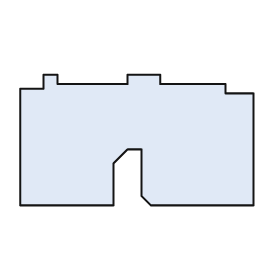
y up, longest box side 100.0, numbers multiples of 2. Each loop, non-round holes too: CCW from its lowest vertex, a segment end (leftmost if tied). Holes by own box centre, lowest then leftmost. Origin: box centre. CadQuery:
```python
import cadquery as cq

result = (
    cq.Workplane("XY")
    .moveTo(-50.0, -28.0)
    .lineTo(-10.0, -28.0)
    .lineTo(-10.0, -10.0)
    .lineTo(-4.0, -4.0)
    .lineTo(2.0, -4.0)
    .lineTo(2.0, -24.0)
    .lineTo(6.0, -28.0)
    .lineTo(50.0, -28.0)
    .lineTo(50.0, 20.0)
    .lineTo(38.0, 20.0)
    .lineTo(38.0, 24.0)
    .lineTo(10.0, 24.0)
    .lineTo(10.0, 28.0)
    .lineTo(-4.0, 28.0)
    .lineTo(-4.0, 24.0)
    .lineTo(-34.0, 24.0)
    .lineTo(-34.0, 28.0)
    .lineTo(-40.0, 28.0)
    .lineTo(-40.0, 22.0)
    .lineTo(-50.0, 22.0)
    .close()
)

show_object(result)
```